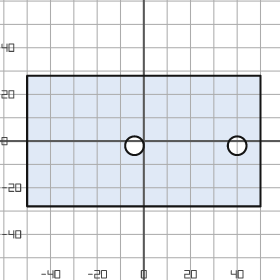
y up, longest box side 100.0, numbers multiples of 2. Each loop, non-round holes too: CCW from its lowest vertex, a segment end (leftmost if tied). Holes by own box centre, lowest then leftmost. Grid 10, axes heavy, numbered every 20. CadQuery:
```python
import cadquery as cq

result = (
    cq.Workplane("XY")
    .moveTo(-50.0, -28.0)
    .lineTo(50.0, -28.0)
    .lineTo(50.0, 28.0)
    .lineTo(-50.0, 28.0)
    .close()
    .moveTo(-4.0, -2.0)
    .circle(4.0)
    .moveTo(40.0, -2.0)
    .circle(4.0)
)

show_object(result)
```